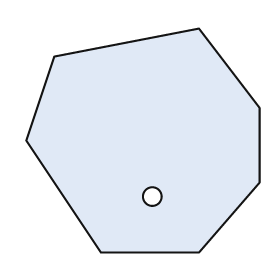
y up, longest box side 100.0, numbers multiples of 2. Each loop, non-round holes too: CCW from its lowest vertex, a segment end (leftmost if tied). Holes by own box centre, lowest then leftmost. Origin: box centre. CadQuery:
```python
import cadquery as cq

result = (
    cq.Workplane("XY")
    .moveTo(-18.0, -48.0)
    .lineTo(24.0, -48.0)
    .lineTo(50.0, -18.0)
    .lineTo(50.0, 14.0)
    .lineTo(24.0, 48.0)
    .lineTo(-38.0, 36.0)
    .lineTo(-50.0, 0.0)
    .close()
    .moveTo(4.0, -24.0)
    .circle(4.0)
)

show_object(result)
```